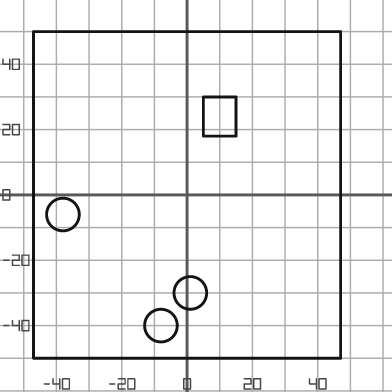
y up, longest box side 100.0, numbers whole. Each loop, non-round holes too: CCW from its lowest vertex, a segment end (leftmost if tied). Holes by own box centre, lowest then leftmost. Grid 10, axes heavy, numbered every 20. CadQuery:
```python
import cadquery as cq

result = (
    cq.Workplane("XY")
    .moveTo(-47.0, -50.0)
    .lineTo(47.0, -50.0)
    .lineTo(47.0, 50.0)
    .lineTo(-47.0, 50.0)
    .close()
    .moveTo(-8.0, -40.0)
    .circle(5.0)
    .moveTo(1.0, -30.0)
    .circle(5.0)
    .moveTo(-38.0, -6.0)
    .circle(5.0)
    .moveTo(5.0, 18.0)
    .lineTo(15.0, 18.0)
    .lineTo(15.0, 30.0)
    .lineTo(5.0, 30.0)
    .close()
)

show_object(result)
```